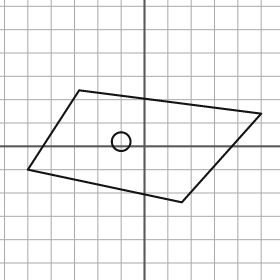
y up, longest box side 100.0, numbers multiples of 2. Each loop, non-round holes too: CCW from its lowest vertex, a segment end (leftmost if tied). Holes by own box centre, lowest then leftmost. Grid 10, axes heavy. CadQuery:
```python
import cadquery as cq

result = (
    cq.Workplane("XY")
    .moveTo(16.0, -24.0)
    .lineTo(50.0, 14.0)
    .lineTo(-28.0, 24.0)
    .lineTo(-50.0, -10.0)
    .close()
    .moveTo(-10.0, 2.0)
    .circle(4.0)
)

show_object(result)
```